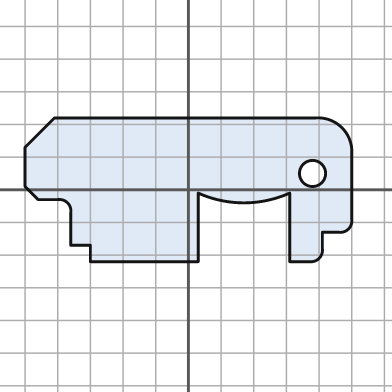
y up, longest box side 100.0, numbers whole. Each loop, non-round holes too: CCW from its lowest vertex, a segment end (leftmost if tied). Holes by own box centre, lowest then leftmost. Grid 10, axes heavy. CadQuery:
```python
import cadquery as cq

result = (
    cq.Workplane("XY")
    .moveTo(-30.0, -22.0)
    .lineTo(3.0, -22.0)
    .lineTo(3.0, -1.0)
    .threePointArc((17.0, -4.0), (31.0, -1.0))
    .lineTo(31.0, -22.0)
    .lineTo(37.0, -22.0)
    .threePointArc((40.0, -21.0), (41.0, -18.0))
    .lineTo(41.0, -13.0)
    .lineTo(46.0, -13.0)
    .threePointArc((49.0, -12.0), (50.0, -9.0))
    .lineTo(50.0, 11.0)
    .threePointArc((47.0, 19.0), (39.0, 22.0))
    .lineTo(-41.0, 22.0)
    .lineTo(-50.0, 13.0)
    .lineTo(-50.0, 1.0)
    .lineTo(-46.0, -3.0)
    .lineTo(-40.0, -3.0)
    .threePointArc((-37.0, -4.0), (-36.0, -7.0))
    .lineTo(-36.0, -17.0)
    .lineTo(-30.0, -17.0)
    .close()
    .moveTo(38.0, 5.0)
    .circle(4.0)
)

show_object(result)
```